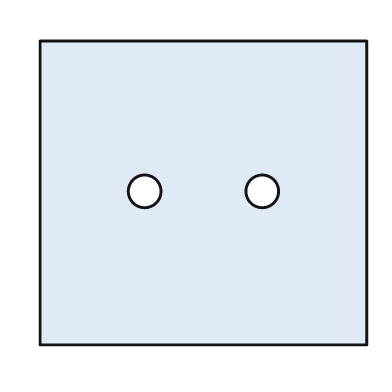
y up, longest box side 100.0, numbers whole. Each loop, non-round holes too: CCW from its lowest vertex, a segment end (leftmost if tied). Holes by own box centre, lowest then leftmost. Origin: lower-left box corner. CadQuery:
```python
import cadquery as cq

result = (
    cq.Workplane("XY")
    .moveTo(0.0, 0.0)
    .lineTo(100.0, 0.0)
    .lineTo(100.0, 93.0)
    .lineTo(0.0, 93.0)
    .close()
    .moveTo(32.0, 47.0)
    .circle(5.0)
    .moveTo(68.0, 47.0)
    .circle(5.0)
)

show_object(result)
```